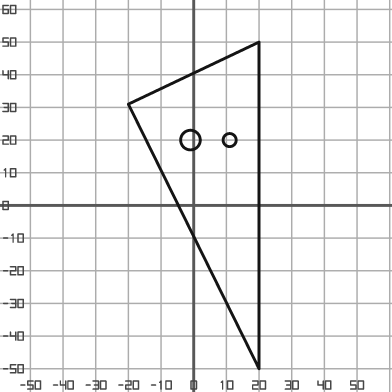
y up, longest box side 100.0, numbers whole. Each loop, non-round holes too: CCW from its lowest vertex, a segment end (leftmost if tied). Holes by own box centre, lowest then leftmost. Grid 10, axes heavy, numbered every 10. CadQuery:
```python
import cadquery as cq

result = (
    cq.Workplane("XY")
    .moveTo(20.0, -50.0)
    .lineTo(20.0, 50.0)
    .lineTo(-20.0, 31.0)
    .close()
    .moveTo(-1.0, 20.0)
    .circle(3.0)
    .moveTo(11.0, 20.0)
    .circle(2.0)
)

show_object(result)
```